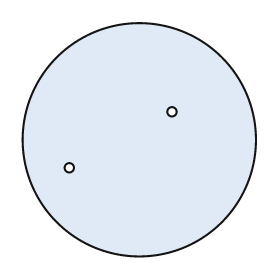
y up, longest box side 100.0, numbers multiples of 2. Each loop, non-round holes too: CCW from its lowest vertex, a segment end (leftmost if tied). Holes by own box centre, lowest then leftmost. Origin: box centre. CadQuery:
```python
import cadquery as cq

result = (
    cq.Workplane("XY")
    .moveTo(0.0, 0.0)
    .circle(50.0)
    .moveTo(-30.0, -12.0)
    .circle(2.0)
    .moveTo(14.0, 12.0)
    .circle(2.0)
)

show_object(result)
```